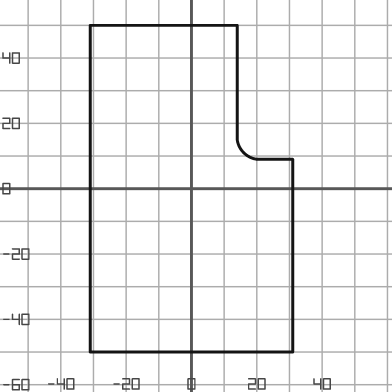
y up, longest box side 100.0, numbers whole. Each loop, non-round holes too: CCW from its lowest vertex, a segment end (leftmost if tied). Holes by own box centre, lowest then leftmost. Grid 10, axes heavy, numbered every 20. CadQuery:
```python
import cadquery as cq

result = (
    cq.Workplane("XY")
    .moveTo(-31.0, -50.0)
    .lineTo(31.0, -50.0)
    .lineTo(31.0, 9.0)
    .lineTo(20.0, 9.0)
    .threePointArc((16.0, 11.0), (14.0, 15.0))
    .lineTo(14.0, 50.0)
    .lineTo(-31.0, 50.0)
    .close()
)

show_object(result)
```